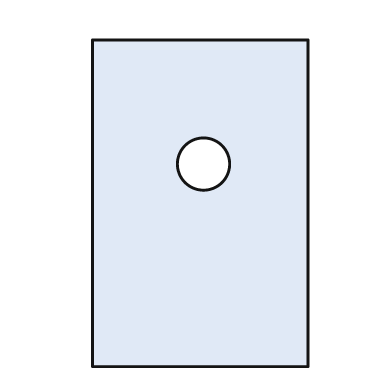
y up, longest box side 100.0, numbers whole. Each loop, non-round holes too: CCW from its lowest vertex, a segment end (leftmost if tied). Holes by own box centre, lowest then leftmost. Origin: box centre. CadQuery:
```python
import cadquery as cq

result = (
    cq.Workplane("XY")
    .moveTo(-33.0, -50.0)
    .lineTo(33.0, -50.0)
    .lineTo(33.0, 50.0)
    .lineTo(-33.0, 50.0)
    .close()
    .moveTo(1.0, 12.0)
    .circle(8.0)
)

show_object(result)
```